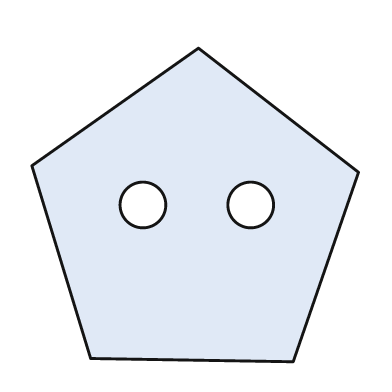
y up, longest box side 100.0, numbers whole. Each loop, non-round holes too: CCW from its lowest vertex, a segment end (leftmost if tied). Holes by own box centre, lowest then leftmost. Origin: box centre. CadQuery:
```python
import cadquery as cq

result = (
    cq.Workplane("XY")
    .moveTo(30.0, -48.0)
    .lineTo(50.0, 10.0)
    .lineTo(1.0, 48.0)
    .lineTo(-50.0, 12.0)
    .lineTo(-32.0, -47.0)
    .close()
    .moveTo(-16.0, 0.0)
    .circle(7.0)
    .moveTo(17.0, 0.0)
    .circle(7.0)
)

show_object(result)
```